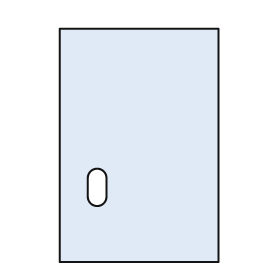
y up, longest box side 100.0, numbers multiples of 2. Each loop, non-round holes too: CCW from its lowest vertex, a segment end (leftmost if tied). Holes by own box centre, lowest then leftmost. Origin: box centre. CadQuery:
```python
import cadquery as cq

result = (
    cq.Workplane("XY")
    .moveTo(-34.0, -50.0)
    .lineTo(34.0, -50.0)
    .lineTo(34.0, 50.0)
    .lineTo(-34.0, 50.0)
    .close()
    .moveTo(-22.0, -22.0)
    .threePointArc((-18.0, -26.0), (-14.0, -22.0))
    .lineTo(-14.0, -14.0)
    .threePointArc((-18.0, -10.0), (-22.0, -14.0))
    .close()
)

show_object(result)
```